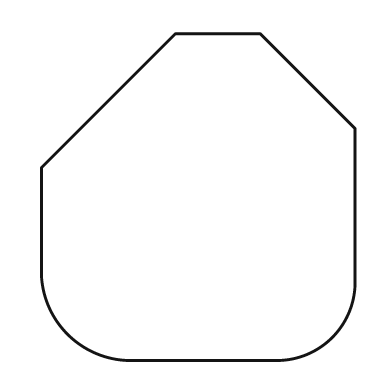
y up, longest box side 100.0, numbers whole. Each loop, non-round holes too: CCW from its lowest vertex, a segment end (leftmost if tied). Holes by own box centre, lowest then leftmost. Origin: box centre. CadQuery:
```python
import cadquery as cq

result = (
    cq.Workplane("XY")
    .moveTo(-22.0, -50.0)
    .lineTo(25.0, -50.0)
    .threePointArc((41.0, -43.0), (48.0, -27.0))
    .lineTo(48.0, 21.0)
    .lineTo(19.0, 50.0)
    .lineTo(-7.0, 50.0)
    .lineTo(-48.0, 9.0)
    .lineTo(-48.0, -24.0)
    .threePointArc((-40.0, -42.0), (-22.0, -50.0))
    .close()
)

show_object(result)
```